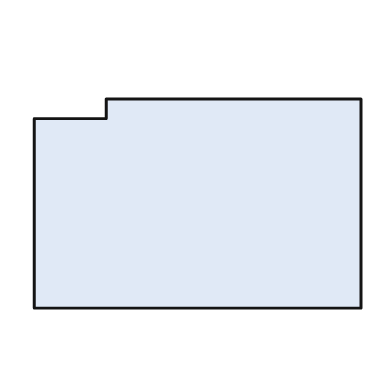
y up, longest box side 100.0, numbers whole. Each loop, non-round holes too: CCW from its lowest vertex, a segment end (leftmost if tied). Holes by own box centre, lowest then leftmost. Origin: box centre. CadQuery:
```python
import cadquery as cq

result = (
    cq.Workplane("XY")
    .moveTo(-50.0, -32.0)
    .lineTo(50.0, -32.0)
    .lineTo(50.0, 32.0)
    .lineTo(-28.0, 32.0)
    .lineTo(-28.0, 26.0)
    .lineTo(-50.0, 26.0)
    .close()
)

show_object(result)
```